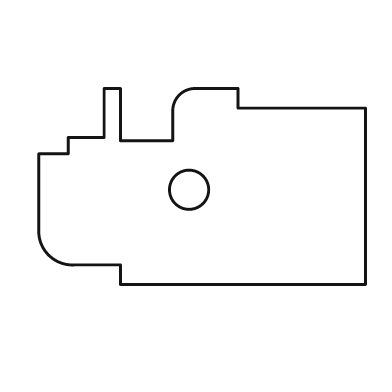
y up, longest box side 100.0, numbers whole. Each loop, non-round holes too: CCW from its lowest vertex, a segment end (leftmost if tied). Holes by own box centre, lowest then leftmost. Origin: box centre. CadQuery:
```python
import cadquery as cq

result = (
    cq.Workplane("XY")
    .moveTo(-25.0, -30.0)
    .lineTo(50.0, -30.0)
    .lineTo(50.0, 24.0)
    .lineTo(11.0, 24.0)
    .lineTo(11.0, 30.0)
    .lineTo(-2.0, 30.0)
    .threePointArc((-7.0, 28.0), (-9.0, 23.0))
    .lineTo(-9.0, 14.0)
    .lineTo(-25.0, 14.0)
    .lineTo(-25.0, 30.0)
    .lineTo(-30.0, 30.0)
    .lineTo(-30.0, 15.0)
    .lineTo(-41.0, 15.0)
    .lineTo(-41.0, 10.0)
    .lineTo(-50.0, 10.0)
    .lineTo(-50.0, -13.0)
    .threePointArc((-47.0, -21.0), (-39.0, -24.0))
    .lineTo(-25.0, -24.0)
    .close()
    .moveTo(-4.0, -1.0)
    .circle(6.0)
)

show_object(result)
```